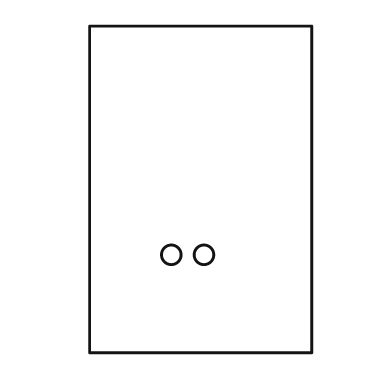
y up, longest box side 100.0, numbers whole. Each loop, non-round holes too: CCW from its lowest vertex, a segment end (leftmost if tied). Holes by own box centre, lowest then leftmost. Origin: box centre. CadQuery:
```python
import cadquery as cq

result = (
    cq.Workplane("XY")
    .moveTo(-34.0, -50.0)
    .lineTo(34.0, -50.0)
    .lineTo(34.0, 50.0)
    .lineTo(-34.0, 50.0)
    .close()
    .moveTo(-9.0, -20.0)
    .circle(3.0)
    .moveTo(1.0, -20.0)
    .circle(3.0)
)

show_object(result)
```